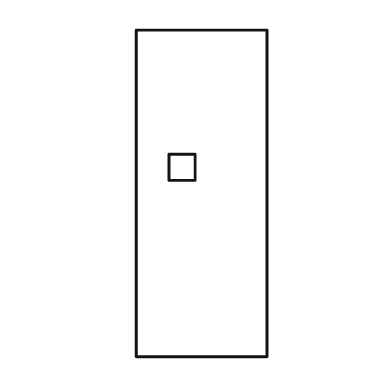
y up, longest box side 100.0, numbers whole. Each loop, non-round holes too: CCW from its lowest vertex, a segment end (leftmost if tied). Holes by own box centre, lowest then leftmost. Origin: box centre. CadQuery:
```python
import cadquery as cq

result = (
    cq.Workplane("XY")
    .moveTo(-20.0, -50.0)
    .lineTo(20.0, -50.0)
    .lineTo(20.0, 50.0)
    .lineTo(-20.0, 50.0)
    .close()
    .moveTo(-10.0, 4.0)
    .lineTo(-2.0, 4.0)
    .lineTo(-2.0, 12.0)
    .lineTo(-10.0, 12.0)
    .close()
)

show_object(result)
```